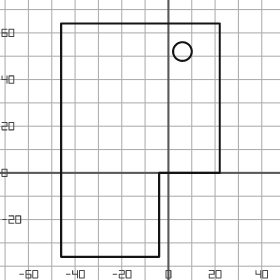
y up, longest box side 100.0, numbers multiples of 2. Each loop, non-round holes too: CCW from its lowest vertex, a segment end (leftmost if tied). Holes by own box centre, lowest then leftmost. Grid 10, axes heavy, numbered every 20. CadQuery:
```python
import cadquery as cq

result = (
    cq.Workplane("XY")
    .moveTo(-46.0, -36.0)
    .lineTo(-4.0, -36.0)
    .lineTo(-4.0, 0.0)
    .lineTo(22.0, 0.0)
    .lineTo(22.0, 64.0)
    .lineTo(-46.0, 64.0)
    .close()
    .moveTo(6.0, 52.0)
    .circle(4.0)
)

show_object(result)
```